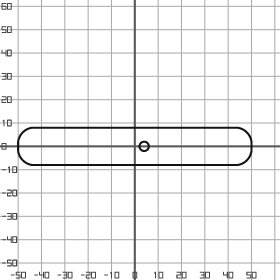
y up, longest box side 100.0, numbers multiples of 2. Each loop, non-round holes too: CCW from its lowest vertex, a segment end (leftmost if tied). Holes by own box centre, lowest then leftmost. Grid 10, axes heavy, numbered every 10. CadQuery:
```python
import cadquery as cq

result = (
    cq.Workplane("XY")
    .moveTo(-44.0, -8.0)
    .lineTo(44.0, -8.0)
    .threePointArc((48.0, -6.0), (50.0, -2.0))
    .lineTo(50.0, 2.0)
    .threePointArc((48.0, 6.0), (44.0, 8.0))
    .lineTo(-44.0, 8.0)
    .threePointArc((-48.0, 6.0), (-50.0, 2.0))
    .lineTo(-50.0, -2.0)
    .threePointArc((-48.0, -6.0), (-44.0, -8.0))
    .close()
    .moveTo(4.0, 0.0)
    .circle(2.0)
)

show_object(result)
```